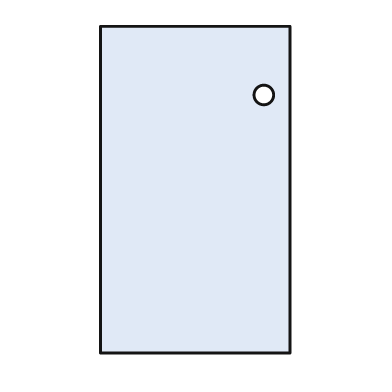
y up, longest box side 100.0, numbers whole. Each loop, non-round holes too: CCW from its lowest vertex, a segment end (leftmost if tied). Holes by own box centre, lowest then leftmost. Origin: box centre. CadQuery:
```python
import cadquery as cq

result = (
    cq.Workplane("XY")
    .moveTo(-29.0, -50.0)
    .lineTo(29.0, -50.0)
    .lineTo(29.0, 50.0)
    .lineTo(-29.0, 50.0)
    .close()
    .moveTo(21.0, 29.0)
    .circle(3.0)
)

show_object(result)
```